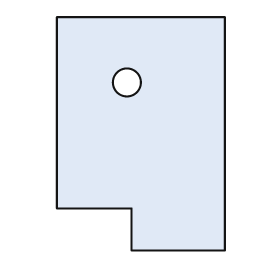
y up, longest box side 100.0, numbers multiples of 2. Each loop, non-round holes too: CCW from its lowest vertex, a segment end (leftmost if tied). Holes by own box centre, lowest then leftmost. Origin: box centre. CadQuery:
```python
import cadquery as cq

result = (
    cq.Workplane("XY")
    .moveTo(-4.0, -50.0)
    .lineTo(36.0, -50.0)
    .lineTo(36.0, 50.0)
    .lineTo(-36.0, 50.0)
    .lineTo(-36.0, -32.0)
    .lineTo(-4.0, -32.0)
    .close()
    .moveTo(-6.0, 22.0)
    .circle(6.0)
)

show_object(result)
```